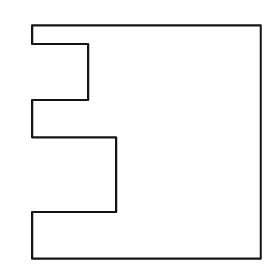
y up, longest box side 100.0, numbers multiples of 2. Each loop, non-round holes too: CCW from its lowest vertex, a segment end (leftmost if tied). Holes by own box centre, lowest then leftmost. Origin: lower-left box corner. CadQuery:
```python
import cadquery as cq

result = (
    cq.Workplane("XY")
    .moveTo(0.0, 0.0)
    .lineTo(98.0, 0.0)
    .lineTo(98.0, 100.0)
    .lineTo(0.0, 100.0)
    .lineTo(0.0, 92.0)
    .lineTo(24.0, 92.0)
    .lineTo(24.0, 68.0)
    .lineTo(0.0, 68.0)
    .lineTo(0.0, 52.0)
    .lineTo(36.0, 52.0)
    .lineTo(36.0, 20.0)
    .lineTo(0.0, 20.0)
    .close()
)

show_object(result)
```